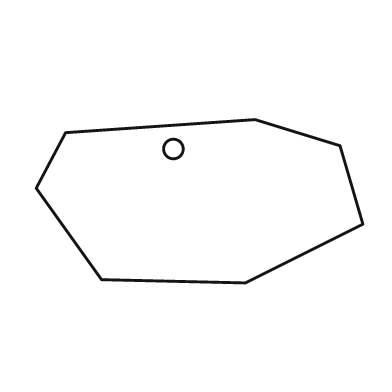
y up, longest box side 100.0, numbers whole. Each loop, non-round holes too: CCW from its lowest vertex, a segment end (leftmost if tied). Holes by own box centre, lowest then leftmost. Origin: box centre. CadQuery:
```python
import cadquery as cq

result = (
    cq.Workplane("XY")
    .moveTo(14.0, -25.0)
    .lineTo(50.0, -7.0)
    .lineTo(43.0, 17.0)
    .lineTo(17.0, 25.0)
    .lineTo(-41.0, 21.0)
    .lineTo(-50.0, 4.0)
    .lineTo(-30.0, -24.0)
    .close()
    .moveTo(-8.0, 16.0)
    .circle(3.0)
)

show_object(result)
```